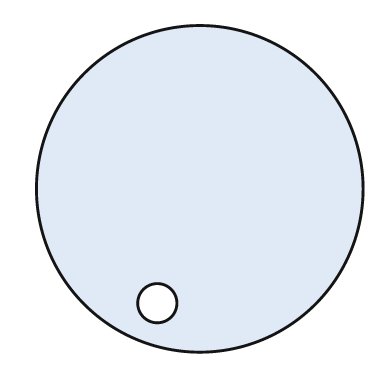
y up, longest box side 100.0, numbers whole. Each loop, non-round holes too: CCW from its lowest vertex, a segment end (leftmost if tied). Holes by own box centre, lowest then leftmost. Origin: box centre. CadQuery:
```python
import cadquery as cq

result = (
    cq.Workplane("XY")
    .moveTo(0.0, 0.0)
    .circle(50.0)
    .moveTo(-13.0, -35.0)
    .circle(6.0)
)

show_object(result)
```